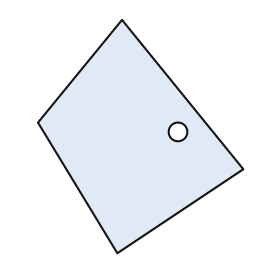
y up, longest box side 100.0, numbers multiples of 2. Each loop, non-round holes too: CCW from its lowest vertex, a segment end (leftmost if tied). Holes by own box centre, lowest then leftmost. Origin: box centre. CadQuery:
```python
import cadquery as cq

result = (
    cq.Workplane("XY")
    .moveTo(-10.0, -50.0)
    .lineTo(44.0, -14.0)
    .lineTo(-8.0, 50.0)
    .lineTo(-44.0, 6.0)
    .close()
    .moveTo(16.0, 2.0)
    .circle(4.0)
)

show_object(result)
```